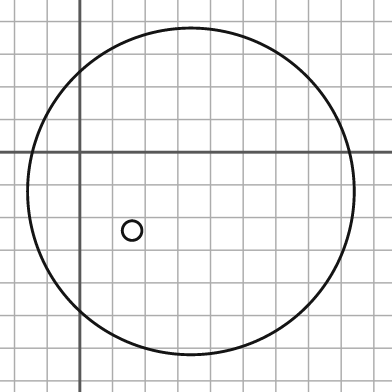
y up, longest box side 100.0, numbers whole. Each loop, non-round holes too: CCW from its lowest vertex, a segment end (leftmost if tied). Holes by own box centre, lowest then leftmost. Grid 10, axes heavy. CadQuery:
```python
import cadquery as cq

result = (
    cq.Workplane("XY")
    .moveTo(34.0, -12.0)
    .circle(50.0)
    .moveTo(16.0, -24.0)
    .circle(3.0)
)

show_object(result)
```